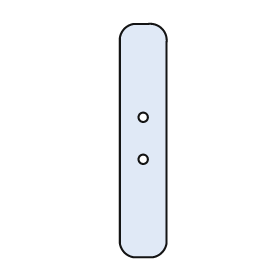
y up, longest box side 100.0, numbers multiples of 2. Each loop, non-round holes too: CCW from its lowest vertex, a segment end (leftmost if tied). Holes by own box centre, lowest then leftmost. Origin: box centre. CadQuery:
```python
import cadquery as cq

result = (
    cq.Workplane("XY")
    .moveTo(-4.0, -50.0)
    .lineTo(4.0, -50.0)
    .threePointArc((8.0, -48.0), (10.0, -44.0))
    .lineTo(10.0, 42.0)
    .threePointArc((8.0, 48.0), (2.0, 50.0))
    .lineTo(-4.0, 50.0)
    .threePointArc((-8.0, 48.0), (-10.0, 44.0))
    .lineTo(-10.0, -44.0)
    .threePointArc((-8.0, -48.0), (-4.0, -50.0))
    .close()
    .moveTo(0.0, -8.0)
    .circle(2.0)
    .moveTo(0.0, 10.0)
    .circle(2.0)
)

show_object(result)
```